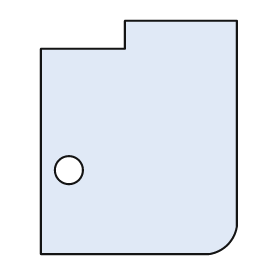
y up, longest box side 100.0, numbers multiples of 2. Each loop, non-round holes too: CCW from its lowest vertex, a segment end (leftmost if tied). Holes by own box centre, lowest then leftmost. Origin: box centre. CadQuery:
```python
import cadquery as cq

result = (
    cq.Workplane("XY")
    .moveTo(-42.0, -50.0)
    .lineTo(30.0, -50.0)
    .threePointArc((38.0, -46.0), (42.0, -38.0))
    .lineTo(42.0, 50.0)
    .lineTo(-6.0, 50.0)
    .lineTo(-6.0, 38.0)
    .lineTo(-42.0, 38.0)
    .close()
    .moveTo(-30.0, -14.0)
    .circle(6.0)
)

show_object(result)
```